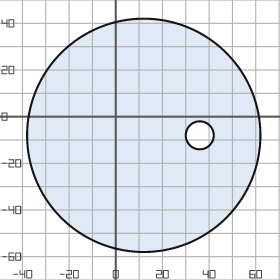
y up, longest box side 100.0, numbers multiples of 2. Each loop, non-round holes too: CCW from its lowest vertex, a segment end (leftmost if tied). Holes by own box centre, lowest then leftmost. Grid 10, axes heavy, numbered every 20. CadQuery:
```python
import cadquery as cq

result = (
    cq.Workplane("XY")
    .moveTo(12.0, -8.0)
    .circle(50.0)
    .moveTo(36.0, -8.0)
    .circle(6.0)
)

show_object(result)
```